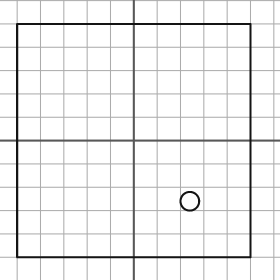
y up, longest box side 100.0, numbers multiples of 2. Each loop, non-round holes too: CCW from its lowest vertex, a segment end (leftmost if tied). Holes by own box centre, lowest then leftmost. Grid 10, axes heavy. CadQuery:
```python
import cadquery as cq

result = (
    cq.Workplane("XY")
    .moveTo(-50.0, -50.0)
    .lineTo(50.0, -50.0)
    .lineTo(50.0, 50.0)
    .lineTo(-50.0, 50.0)
    .close()
    .moveTo(24.0, -26.0)
    .circle(4.0)
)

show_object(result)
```